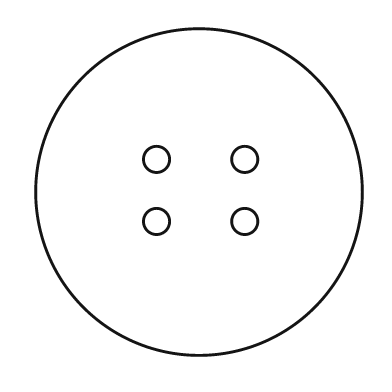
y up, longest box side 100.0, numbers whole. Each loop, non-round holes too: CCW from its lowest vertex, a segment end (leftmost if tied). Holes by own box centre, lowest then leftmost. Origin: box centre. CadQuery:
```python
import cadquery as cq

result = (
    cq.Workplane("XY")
    .moveTo(0.0, 0.0)
    .circle(50.0)
    .moveTo(-13.0, -9.0)
    .circle(4.0)
    .moveTo(14.0, -9.0)
    .circle(4.0)
    .moveTo(-13.0, 10.0)
    .circle(4.0)
    .moveTo(14.0, 10.0)
    .circle(4.0)
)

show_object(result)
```